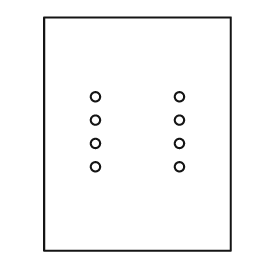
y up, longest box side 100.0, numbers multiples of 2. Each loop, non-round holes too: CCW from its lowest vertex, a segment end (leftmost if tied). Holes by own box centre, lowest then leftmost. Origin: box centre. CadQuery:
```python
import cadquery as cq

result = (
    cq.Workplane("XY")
    .moveTo(-40.0, -50.0)
    .lineTo(40.0, -50.0)
    .lineTo(40.0, 50.0)
    .lineTo(-40.0, 50.0)
    .close()
    .moveTo(-18.0, -14.0)
    .circle(2.0)
    .moveTo(18.0, -14.0)
    .circle(2.0)
    .moveTo(-18.0, -4.0)
    .circle(2.0)
    .moveTo(18.0, -4.0)
    .circle(2.0)
    .moveTo(-18.0, 6.0)
    .circle(2.0)
    .moveTo(18.0, 6.0)
    .circle(2.0)
    .moveTo(-18.0, 16.0)
    .circle(2.0)
    .moveTo(18.0, 16.0)
    .circle(2.0)
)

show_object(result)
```